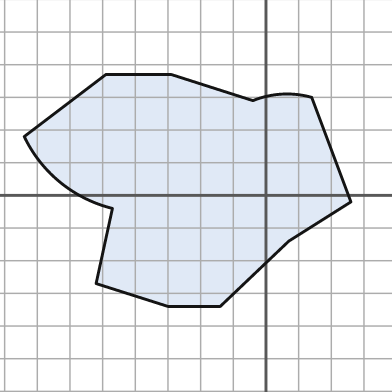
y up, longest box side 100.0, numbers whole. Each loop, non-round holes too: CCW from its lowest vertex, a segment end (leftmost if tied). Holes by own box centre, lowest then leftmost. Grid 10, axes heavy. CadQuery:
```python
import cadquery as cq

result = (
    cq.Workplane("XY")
    .moveTo(-30.0, -34.0)
    .lineTo(-14.0, -34.0)
    .lineTo(7.0, -14.0)
    .lineTo(26.0, -2.0)
    .lineTo(14.0, 30.0)
    .threePointArc((5.0, 31.0), (-4.0, 29.0))
    .lineTo(-29.0, 37.0)
    .lineTo(-49.0, 37.0)
    .lineTo(-74.0, 18.0)
    .threePointArc((-63.0, 4.0), (-47.0, -4.0))
    .lineTo(-52.0, -27.0)
    .close()
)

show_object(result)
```